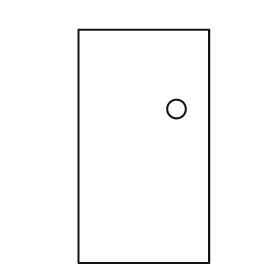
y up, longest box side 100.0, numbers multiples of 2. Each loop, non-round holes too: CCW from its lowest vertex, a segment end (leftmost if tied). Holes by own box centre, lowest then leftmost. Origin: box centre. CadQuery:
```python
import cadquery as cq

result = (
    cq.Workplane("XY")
    .moveTo(-28.0, -50.0)
    .lineTo(28.0, -50.0)
    .lineTo(28.0, 50.0)
    .lineTo(-28.0, 50.0)
    .close()
    .moveTo(14.0, 16.0)
    .circle(4.0)
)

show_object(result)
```